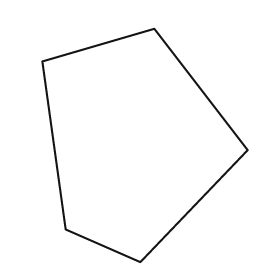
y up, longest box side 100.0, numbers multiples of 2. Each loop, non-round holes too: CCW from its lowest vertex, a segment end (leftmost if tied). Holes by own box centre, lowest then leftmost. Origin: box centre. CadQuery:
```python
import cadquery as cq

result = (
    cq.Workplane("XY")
    .moveTo(-2.0, -50.0)
    .lineTo(44.0, -2.0)
    .lineTo(4.0, 50.0)
    .lineTo(-44.0, 36.0)
    .lineTo(-34.0, -36.0)
    .close()
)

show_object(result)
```